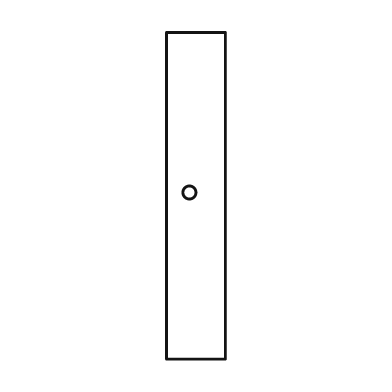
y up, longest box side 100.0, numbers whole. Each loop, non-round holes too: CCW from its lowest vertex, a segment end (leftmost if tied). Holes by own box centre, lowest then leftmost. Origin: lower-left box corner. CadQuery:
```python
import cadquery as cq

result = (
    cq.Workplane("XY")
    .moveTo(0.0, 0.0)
    .lineTo(18.0, 0.0)
    .lineTo(18.0, 100.0)
    .lineTo(0.0, 100.0)
    .close()
    .moveTo(7.0, 51.0)
    .circle(2.0)
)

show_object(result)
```